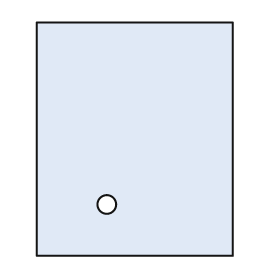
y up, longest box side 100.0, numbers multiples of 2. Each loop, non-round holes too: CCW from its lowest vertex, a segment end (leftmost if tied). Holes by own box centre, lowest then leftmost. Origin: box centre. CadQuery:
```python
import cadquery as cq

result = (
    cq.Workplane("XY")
    .moveTo(-42.0, -50.0)
    .lineTo(42.0, -50.0)
    .lineTo(42.0, 50.0)
    .lineTo(-42.0, 50.0)
    .close()
    .moveTo(-12.0, -28.0)
    .circle(4.0)
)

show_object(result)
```